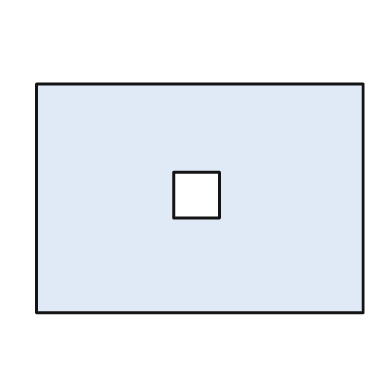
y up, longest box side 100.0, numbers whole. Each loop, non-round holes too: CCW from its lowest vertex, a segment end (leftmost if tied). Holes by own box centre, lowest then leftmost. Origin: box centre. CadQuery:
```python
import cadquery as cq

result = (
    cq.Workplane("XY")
    .moveTo(-50.0, -35.0)
    .lineTo(50.0, -35.0)
    .lineTo(50.0, 35.0)
    .lineTo(-50.0, 35.0)
    .close()
    .moveTo(-8.0, -6.0)
    .lineTo(6.0, -6.0)
    .lineTo(6.0, 8.0)
    .lineTo(-8.0, 8.0)
    .close()
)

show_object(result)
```